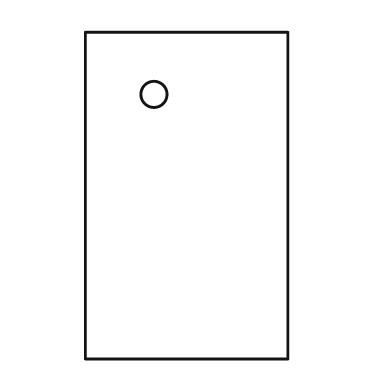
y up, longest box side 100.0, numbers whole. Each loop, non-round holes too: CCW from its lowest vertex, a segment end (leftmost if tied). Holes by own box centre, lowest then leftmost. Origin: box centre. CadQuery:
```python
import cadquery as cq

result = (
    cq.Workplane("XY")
    .moveTo(-31.0, -50.0)
    .lineTo(31.0, -50.0)
    .lineTo(31.0, 50.0)
    .lineTo(-31.0, 50.0)
    .close()
    .moveTo(-10.0, 31.0)
    .circle(4.0)
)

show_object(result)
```